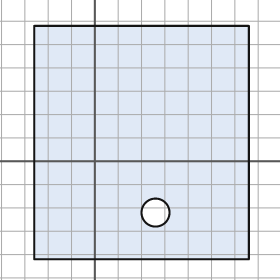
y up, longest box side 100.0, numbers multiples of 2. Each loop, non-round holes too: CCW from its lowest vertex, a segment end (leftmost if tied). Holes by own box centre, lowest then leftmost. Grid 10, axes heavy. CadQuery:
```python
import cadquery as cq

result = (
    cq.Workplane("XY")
    .moveTo(-26.0, -42.0)
    .lineTo(66.0, -42.0)
    .lineTo(66.0, 58.0)
    .lineTo(-26.0, 58.0)
    .close()
    .moveTo(26.0, -22.0)
    .circle(6.0)
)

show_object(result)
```